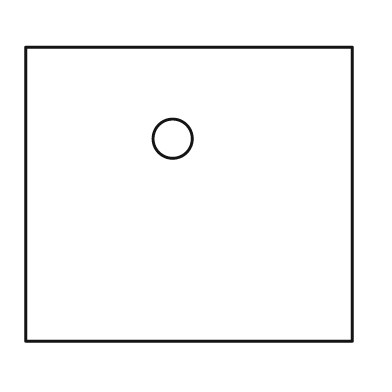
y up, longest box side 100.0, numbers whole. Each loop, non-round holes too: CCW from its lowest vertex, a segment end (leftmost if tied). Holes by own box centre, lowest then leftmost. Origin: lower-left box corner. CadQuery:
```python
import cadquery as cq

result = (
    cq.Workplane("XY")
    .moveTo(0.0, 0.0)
    .lineTo(100.0, 0.0)
    .lineTo(100.0, 90.0)
    .lineTo(0.0, 90.0)
    .close()
    .moveTo(45.0, 62.0)
    .circle(6.0)
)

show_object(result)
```